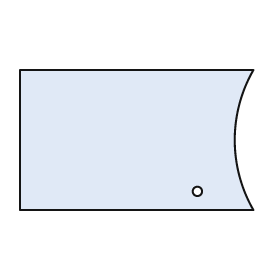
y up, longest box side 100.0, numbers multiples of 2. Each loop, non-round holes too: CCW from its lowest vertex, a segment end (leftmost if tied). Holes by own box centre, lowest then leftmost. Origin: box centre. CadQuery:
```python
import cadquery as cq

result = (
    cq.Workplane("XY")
    .moveTo(-50.0, -30.0)
    .lineTo(50.0, -30.0)
    .threePointArc((42.0, 0.0), (50.0, 30.0))
    .lineTo(-50.0, 30.0)
    .close()
    .moveTo(26.0, -22.0)
    .circle(2.0)
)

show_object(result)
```